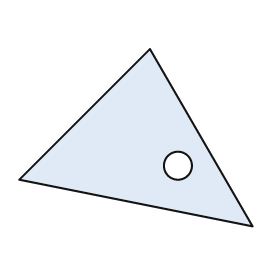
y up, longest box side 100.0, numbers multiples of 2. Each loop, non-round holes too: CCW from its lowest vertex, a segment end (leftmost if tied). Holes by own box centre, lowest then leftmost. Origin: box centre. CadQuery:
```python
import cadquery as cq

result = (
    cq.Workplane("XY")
    .moveTo(50.0, -38.0)
    .lineTo(6.0, 38.0)
    .lineTo(-50.0, -18.0)
    .close()
    .moveTo(18.0, -12.0)
    .circle(6.0)
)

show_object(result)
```